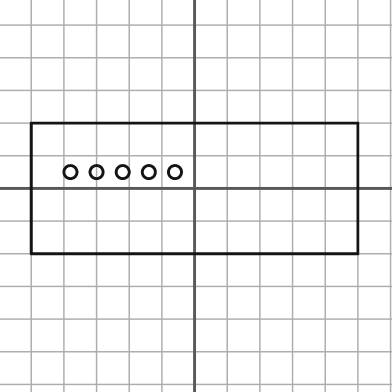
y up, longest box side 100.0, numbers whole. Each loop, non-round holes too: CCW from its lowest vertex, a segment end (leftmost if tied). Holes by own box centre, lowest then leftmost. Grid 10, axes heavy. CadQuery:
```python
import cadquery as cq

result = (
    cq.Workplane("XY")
    .moveTo(-50.0, -20.0)
    .lineTo(50.0, -20.0)
    .lineTo(50.0, 20.0)
    .lineTo(-50.0, 20.0)
    .close()
    .moveTo(-38.0, 5.0)
    .circle(2.0)
    .moveTo(-30.0, 5.0)
    .circle(2.0)
    .moveTo(-22.0, 5.0)
    .circle(2.0)
    .moveTo(-14.0, 5.0)
    .circle(2.0)
    .moveTo(-6.0, 5.0)
    .circle(2.0)
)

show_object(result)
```